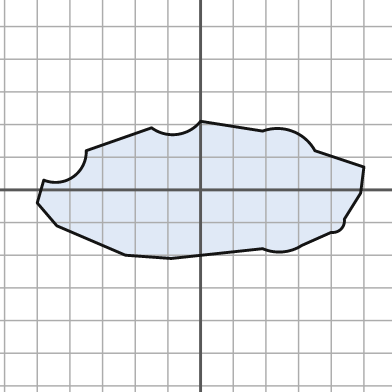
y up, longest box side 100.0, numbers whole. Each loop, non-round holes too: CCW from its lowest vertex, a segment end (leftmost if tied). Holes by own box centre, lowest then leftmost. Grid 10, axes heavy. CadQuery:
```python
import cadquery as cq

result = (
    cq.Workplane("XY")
    .moveTo(-9.0, -21.0)
    .lineTo(19.0, -18.0)
    .threePointArc((25.0, -19.0), (31.0, -17.0))
    .lineTo(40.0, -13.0)
    .threePointArc((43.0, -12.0), (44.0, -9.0))
    .lineTo(49.0, -1.0)
    .lineTo(50.0, 7.0)
    .lineTo(35.0, 12.0)
    .threePointArc((28.0, 18.0), (19.0, 18.0))
    .lineTo(0.0, 21.0)
    .threePointArc((-7.0, 17.0), (-15.0, 19.0))
    .lineTo(-35.0, 12.0)
    .threePointArc((-39.0, 4.0), (-48.0, 3.0))
    .lineTo(-50.0, -4.0)
    .lineTo(-44.0, -11.0)
    .lineTo(-23.0, -20.0)
    .close()
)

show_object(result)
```